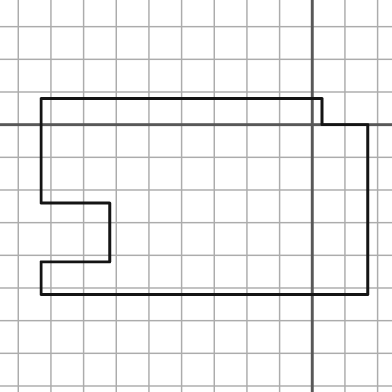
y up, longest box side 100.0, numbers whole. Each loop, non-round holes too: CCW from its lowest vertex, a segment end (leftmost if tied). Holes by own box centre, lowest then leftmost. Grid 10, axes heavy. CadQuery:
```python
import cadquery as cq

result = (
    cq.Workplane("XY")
    .moveTo(-83.0, -52.0)
    .lineTo(17.0, -52.0)
    .lineTo(17.0, 0.0)
    .lineTo(3.0, 0.0)
    .lineTo(3.0, 8.0)
    .lineTo(-83.0, 8.0)
    .lineTo(-83.0, -24.0)
    .lineTo(-62.0, -24.0)
    .lineTo(-62.0, -42.0)
    .lineTo(-83.0, -42.0)
    .close()
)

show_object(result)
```